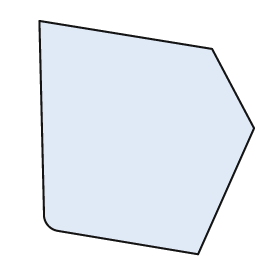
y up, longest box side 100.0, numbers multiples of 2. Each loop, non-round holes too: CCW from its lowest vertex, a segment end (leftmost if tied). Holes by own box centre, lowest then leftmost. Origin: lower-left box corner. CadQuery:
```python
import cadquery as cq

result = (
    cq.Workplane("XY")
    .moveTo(68.0, 0.0)
    .lineTo(92.0, 54.0)
    .lineTo(74.0, 88.0)
    .lineTo(0.0, 100.0)
    .lineTo(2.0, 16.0)
    .threePointArc((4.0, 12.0), (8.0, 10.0))
    .close()
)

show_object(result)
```